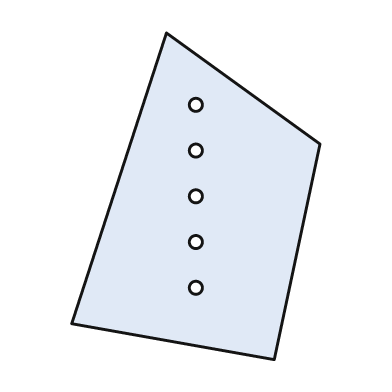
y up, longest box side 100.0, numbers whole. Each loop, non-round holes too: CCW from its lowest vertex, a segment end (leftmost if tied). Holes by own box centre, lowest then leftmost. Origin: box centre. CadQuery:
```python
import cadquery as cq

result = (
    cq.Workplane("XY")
    .moveTo(24.0, -50.0)
    .lineTo(38.0, 16.0)
    .lineTo(-9.0, 50.0)
    .lineTo(-38.0, -39.0)
    .close()
    .moveTo(0.0, -28.0)
    .circle(2.0)
    .moveTo(0.0, -14.0)
    .circle(2.0)
    .moveTo(0.0, 0.0)
    .circle(2.0)
    .moveTo(0.0, 14.0)
    .circle(2.0)
    .moveTo(0.0, 28.0)
    .circle(2.0)
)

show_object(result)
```